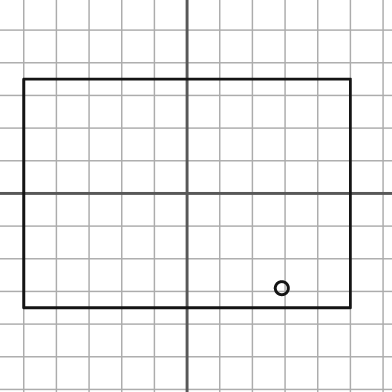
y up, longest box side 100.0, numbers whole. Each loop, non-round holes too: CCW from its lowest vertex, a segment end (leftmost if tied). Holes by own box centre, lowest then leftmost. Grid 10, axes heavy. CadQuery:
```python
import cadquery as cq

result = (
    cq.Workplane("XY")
    .moveTo(-50.0, -35.0)
    .lineTo(50.0, -35.0)
    .lineTo(50.0, 35.0)
    .lineTo(-50.0, 35.0)
    .close()
    .moveTo(29.0, -29.0)
    .circle(2.0)
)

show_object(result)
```